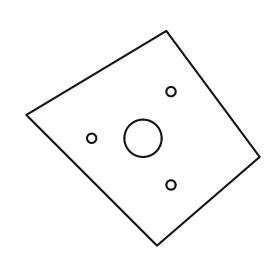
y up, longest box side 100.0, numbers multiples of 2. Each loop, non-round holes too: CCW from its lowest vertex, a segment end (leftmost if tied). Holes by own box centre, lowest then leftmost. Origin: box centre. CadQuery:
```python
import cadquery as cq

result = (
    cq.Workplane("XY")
    .moveTo(6.0, -46.0)
    .lineTo(50.0, -8.0)
    .lineTo(10.0, 46.0)
    .lineTo(-50.0, 10.0)
    .close()
    .moveTo(12.0, -20.0)
    .circle(2.0)
    .moveTo(-22.0, 0.0)
    .circle(2.0)
    .moveTo(0.0, 0.0)
    .circle(8.0)
    .moveTo(12.0, 20.0)
    .circle(2.0)
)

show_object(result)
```